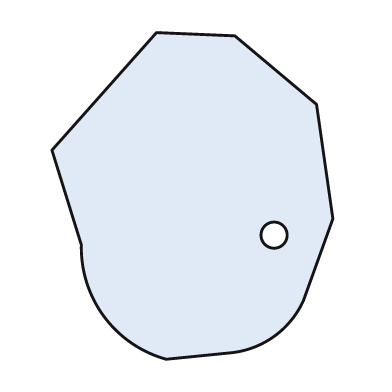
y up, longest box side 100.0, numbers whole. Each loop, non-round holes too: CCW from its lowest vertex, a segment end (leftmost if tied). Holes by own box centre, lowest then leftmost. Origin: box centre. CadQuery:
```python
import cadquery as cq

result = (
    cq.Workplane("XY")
    .moveTo(-8.0, -50.0)
    .lineTo(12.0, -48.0)
    .threePointArc((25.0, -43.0), (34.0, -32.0))
    .lineTo(43.0, -7.0)
    .lineTo(38.0, 28.0)
    .lineTo(13.0, 49.0)
    .lineTo(-11.0, 50.0)
    .lineTo(-43.0, 14.0)
    .lineTo(-34.0, -15.0)
    .threePointArc((-27.0, -37.0), (-8.0, -50.0))
    .close()
    .moveTo(25.0, -12.0)
    .circle(4.0)
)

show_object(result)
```